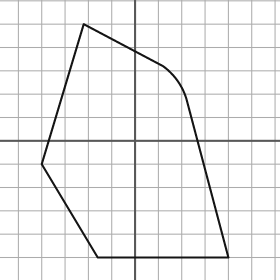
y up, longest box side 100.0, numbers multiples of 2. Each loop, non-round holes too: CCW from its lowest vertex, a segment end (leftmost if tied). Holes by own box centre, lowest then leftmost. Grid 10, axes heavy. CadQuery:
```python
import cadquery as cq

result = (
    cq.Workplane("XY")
    .moveTo(-16.0, -50.0)
    .lineTo(40.0, -50.0)
    .lineTo(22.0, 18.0)
    .threePointArc((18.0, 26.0), (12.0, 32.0))
    .lineTo(-22.0, 50.0)
    .lineTo(-40.0, -10.0)
    .close()
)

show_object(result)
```